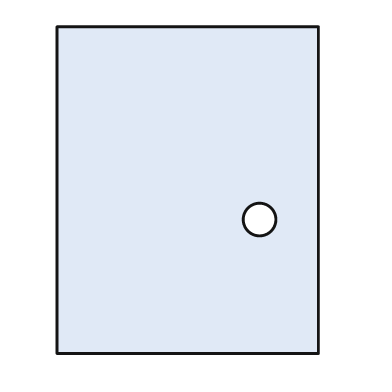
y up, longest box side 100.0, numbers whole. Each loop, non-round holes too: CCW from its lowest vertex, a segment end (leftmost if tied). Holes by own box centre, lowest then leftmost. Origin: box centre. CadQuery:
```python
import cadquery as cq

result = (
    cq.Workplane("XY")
    .moveTo(-40.0, -50.0)
    .lineTo(40.0, -50.0)
    .lineTo(40.0, 50.0)
    .lineTo(-40.0, 50.0)
    .close()
    .moveTo(22.0, -9.0)
    .circle(5.0)
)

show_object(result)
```